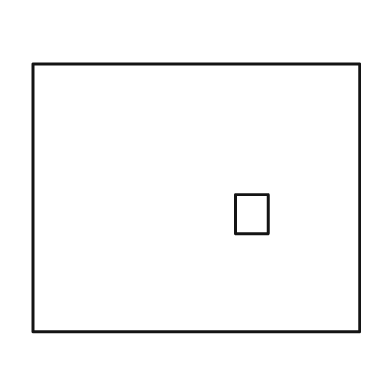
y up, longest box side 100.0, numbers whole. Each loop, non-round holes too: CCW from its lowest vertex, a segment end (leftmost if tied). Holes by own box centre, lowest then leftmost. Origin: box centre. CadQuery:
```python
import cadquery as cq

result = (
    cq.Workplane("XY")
    .moveTo(-50.0, -41.0)
    .lineTo(50.0, -41.0)
    .lineTo(50.0, 41.0)
    .lineTo(-50.0, 41.0)
    .close()
    .moveTo(12.0, -11.0)
    .lineTo(22.0, -11.0)
    .lineTo(22.0, 1.0)
    .lineTo(12.0, 1.0)
    .close()
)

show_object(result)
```